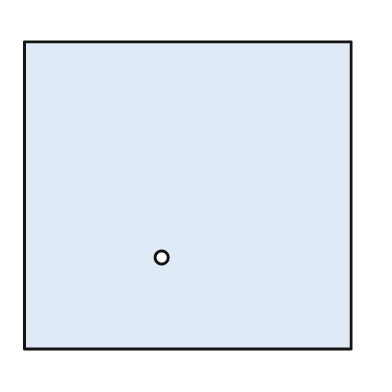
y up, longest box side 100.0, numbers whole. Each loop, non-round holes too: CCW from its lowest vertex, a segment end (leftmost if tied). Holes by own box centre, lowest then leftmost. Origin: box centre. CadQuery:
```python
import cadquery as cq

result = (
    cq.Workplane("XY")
    .moveTo(-50.0, -47.0)
    .lineTo(50.0, -47.0)
    .lineTo(50.0, 47.0)
    .lineTo(-50.0, 47.0)
    .close()
    .moveTo(-8.0, -19.0)
    .circle(2.0)
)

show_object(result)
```